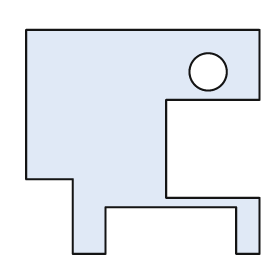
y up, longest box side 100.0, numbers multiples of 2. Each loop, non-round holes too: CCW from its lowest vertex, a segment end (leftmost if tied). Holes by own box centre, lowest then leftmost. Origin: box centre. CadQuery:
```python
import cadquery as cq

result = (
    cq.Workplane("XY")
    .moveTo(-30.0, -48.0)
    .lineTo(-16.0, -48.0)
    .lineTo(-16.0, -28.0)
    .lineTo(40.0, -28.0)
    .lineTo(40.0, -48.0)
    .lineTo(50.0, -48.0)
    .lineTo(50.0, -24.0)
    .lineTo(10.0, -24.0)
    .lineTo(10.0, 18.0)
    .lineTo(50.0, 18.0)
    .lineTo(50.0, 48.0)
    .lineTo(-50.0, 48.0)
    .lineTo(-50.0, -16.0)
    .lineTo(-30.0, -16.0)
    .close()
    .moveTo(28.0, 30.0)
    .circle(8.0)
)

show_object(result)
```